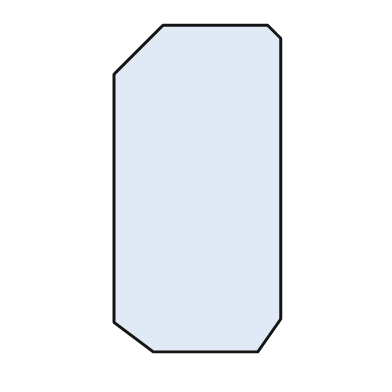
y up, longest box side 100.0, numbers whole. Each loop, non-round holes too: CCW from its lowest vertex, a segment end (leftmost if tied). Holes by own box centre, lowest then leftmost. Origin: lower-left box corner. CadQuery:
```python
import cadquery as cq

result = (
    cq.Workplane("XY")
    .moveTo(12.0, 0.0)
    .lineTo(44.0, 0.0)
    .lineTo(51.0, 10.0)
    .lineTo(51.0, 96.0)
    .lineTo(47.0, 100.0)
    .lineTo(15.0, 100.0)
    .lineTo(0.0, 85.0)
    .lineTo(0.0, 9.0)
    .close()
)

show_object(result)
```